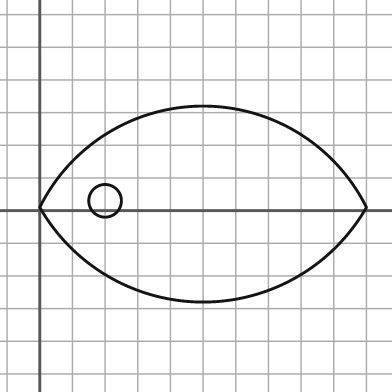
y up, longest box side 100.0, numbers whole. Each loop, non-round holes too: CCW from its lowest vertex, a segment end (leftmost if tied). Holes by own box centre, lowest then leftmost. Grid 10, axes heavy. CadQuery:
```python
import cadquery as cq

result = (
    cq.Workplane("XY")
    .moveTo(0.0, 1.0)
    .threePointArc((50.0, -28.0), (100.0, 1.0))
    .threePointArc((50.0, 32.0), (0.0, 1.0))
    .close()
    .moveTo(20.0, 3.0)
    .circle(5.0)
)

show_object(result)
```